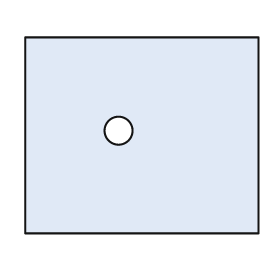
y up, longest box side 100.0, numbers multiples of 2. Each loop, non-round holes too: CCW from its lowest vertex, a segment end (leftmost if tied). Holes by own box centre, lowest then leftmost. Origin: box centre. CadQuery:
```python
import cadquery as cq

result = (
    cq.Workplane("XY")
    .moveTo(-50.0, -42.0)
    .lineTo(50.0, -42.0)
    .lineTo(50.0, 42.0)
    .lineTo(-50.0, 42.0)
    .close()
    .moveTo(-10.0, 2.0)
    .circle(6.0)
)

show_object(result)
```